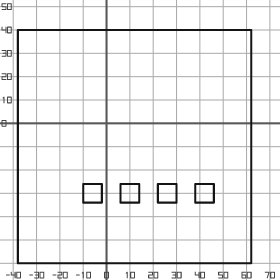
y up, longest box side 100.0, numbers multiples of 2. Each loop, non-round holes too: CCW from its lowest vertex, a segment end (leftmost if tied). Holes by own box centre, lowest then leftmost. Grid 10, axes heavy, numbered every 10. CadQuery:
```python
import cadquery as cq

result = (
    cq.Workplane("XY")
    .moveTo(-38.0, -60.0)
    .lineTo(62.0, -60.0)
    .lineTo(62.0, 40.0)
    .lineTo(-38.0, 40.0)
    .close()
    .moveTo(-10.0, -34.0)
    .lineTo(-2.0, -34.0)
    .lineTo(-2.0, -26.0)
    .lineTo(-10.0, -26.0)
    .close()
    .moveTo(6.0, -34.0)
    .lineTo(14.0, -34.0)
    .lineTo(14.0, -26.0)
    .lineTo(6.0, -26.0)
    .close()
    .moveTo(22.0, -34.0)
    .lineTo(30.0, -34.0)
    .lineTo(30.0, -26.0)
    .lineTo(22.0, -26.0)
    .close()
    .moveTo(38.0, -34.0)
    .lineTo(46.0, -34.0)
    .lineTo(46.0, -26.0)
    .lineTo(38.0, -26.0)
    .close()
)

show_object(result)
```